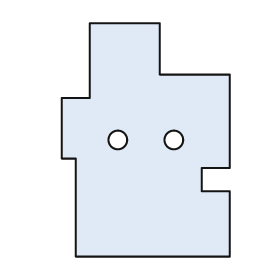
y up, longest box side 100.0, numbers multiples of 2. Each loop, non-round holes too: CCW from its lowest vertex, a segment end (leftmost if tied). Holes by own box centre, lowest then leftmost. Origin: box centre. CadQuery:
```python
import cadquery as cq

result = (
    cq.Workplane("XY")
    .moveTo(-30.0, -50.0)
    .lineTo(36.0, -50.0)
    .lineTo(36.0, -22.0)
    .lineTo(24.0, -22.0)
    .lineTo(24.0, -12.0)
    .lineTo(36.0, -12.0)
    .lineTo(36.0, 28.0)
    .lineTo(6.0, 28.0)
    .lineTo(6.0, 50.0)
    .lineTo(-24.0, 50.0)
    .lineTo(-24.0, 18.0)
    .lineTo(-36.0, 18.0)
    .lineTo(-36.0, -8.0)
    .lineTo(-30.0, -8.0)
    .close()
    .moveTo(-12.0, 0.0)
    .circle(4.0)
    .moveTo(12.0, 0.0)
    .circle(4.0)
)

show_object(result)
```